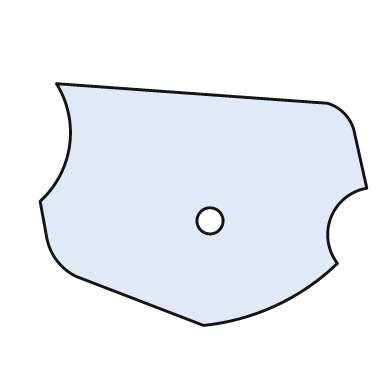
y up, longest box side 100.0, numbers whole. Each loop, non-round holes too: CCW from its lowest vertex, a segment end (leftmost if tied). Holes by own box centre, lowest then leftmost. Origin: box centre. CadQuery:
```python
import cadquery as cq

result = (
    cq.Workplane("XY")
    .moveTo(0.0, -37.0)
    .threePointArc((22.0, -31.0), (41.0, -18.0))
    .threePointArc((39.0, -4.0), (50.0, 5.0))
    .lineTo(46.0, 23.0)
    .threePointArc((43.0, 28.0), (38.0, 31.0))
    .lineTo(-45.0, 37.0)
    .threePointArc((-41.0, 18.0), (-50.0, 1.0))
    .lineTo(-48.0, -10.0)
    .threePointArc((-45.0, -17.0), (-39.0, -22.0))
    .close()
    .moveTo(2.0, -5.0)
    .circle(4.0)
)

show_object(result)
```